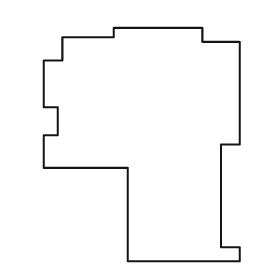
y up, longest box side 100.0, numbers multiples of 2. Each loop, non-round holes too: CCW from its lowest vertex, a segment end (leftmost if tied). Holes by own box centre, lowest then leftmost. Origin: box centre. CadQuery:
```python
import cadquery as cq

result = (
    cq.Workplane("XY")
    .moveTo(-6.0, -50.0)
    .lineTo(42.0, -50.0)
    .lineTo(42.0, -44.0)
    .lineTo(34.0, -44.0)
    .lineTo(34.0, 0.0)
    .lineTo(42.0, 0.0)
    .lineTo(42.0, 44.0)
    .lineTo(26.0, 44.0)
    .lineTo(26.0, 50.0)
    .lineTo(-12.0, 50.0)
    .lineTo(-12.0, 46.0)
    .lineTo(-34.0, 46.0)
    .lineTo(-34.0, 36.0)
    .lineTo(-42.0, 36.0)
    .lineTo(-42.0, 16.0)
    .lineTo(-36.0, 16.0)
    .lineTo(-36.0, 4.0)
    .lineTo(-42.0, 4.0)
    .lineTo(-42.0, -10.0)
    .lineTo(-6.0, -10.0)
    .close()
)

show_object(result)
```